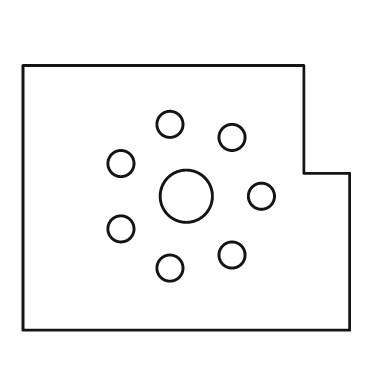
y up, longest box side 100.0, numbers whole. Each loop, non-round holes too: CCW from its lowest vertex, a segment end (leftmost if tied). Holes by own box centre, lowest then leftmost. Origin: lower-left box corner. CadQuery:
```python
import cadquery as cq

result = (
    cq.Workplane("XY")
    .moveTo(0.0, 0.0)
    .lineTo(100.0, 0.0)
    .lineTo(100.0, 48.0)
    .lineTo(86.0, 48.0)
    .lineTo(86.0, 81.0)
    .lineTo(0.0, 81.0)
    .close()
    .moveTo(45.0, 19.0)
    .circle(4.0)
    .moveTo(64.0, 23.0)
    .circle(4.0)
    .moveTo(30.0, 31.0)
    .circle(4.0)
    .moveTo(50.0, 41.0)
    .circle(8.0)
    .moveTo(73.0, 41.0)
    .circle(4.0)
    .moveTo(30.0, 51.0)
    .circle(4.0)
    .moveTo(64.0, 59.0)
    .circle(4.0)
    .moveTo(45.0, 63.0)
    .circle(4.0)
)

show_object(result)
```